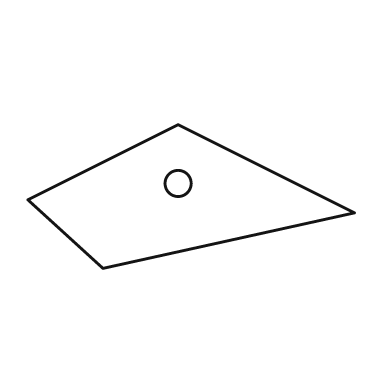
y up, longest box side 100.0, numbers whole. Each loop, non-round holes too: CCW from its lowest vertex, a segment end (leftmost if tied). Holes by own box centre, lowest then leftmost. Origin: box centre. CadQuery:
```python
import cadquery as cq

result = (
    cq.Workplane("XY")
    .moveTo(-27.0, -22.0)
    .lineTo(50.0, -5.0)
    .lineTo(-4.0, 22.0)
    .lineTo(-50.0, -1.0)
    .close()
    .moveTo(-4.0, 4.0)
    .circle(4.0)
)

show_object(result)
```